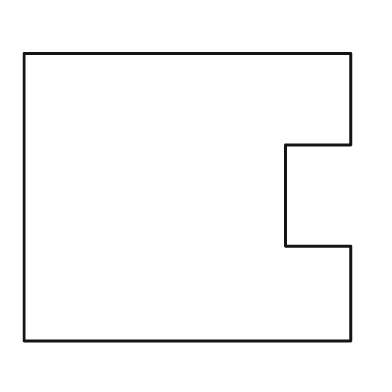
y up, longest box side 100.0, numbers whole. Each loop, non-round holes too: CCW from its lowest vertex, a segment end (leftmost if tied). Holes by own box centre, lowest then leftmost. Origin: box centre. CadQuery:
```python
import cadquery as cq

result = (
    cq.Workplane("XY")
    .moveTo(-50.0, -44.0)
    .lineTo(50.0, -44.0)
    .lineTo(50.0, -15.0)
    .lineTo(30.0, -15.0)
    .lineTo(30.0, 16.0)
    .lineTo(50.0, 16.0)
    .lineTo(50.0, 44.0)
    .lineTo(-50.0, 44.0)
    .close()
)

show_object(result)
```